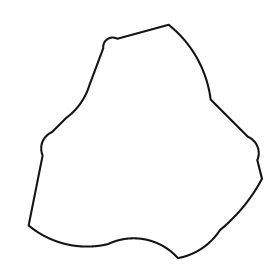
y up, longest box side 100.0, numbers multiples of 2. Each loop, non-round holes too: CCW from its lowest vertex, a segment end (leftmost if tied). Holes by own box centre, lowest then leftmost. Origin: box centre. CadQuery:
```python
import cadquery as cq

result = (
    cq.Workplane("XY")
    .moveTo(14.0, -50.0)
    .threePointArc((24.0, -46.0), (32.0, -38.0))
    .threePointArc((42.0, -28.0), (50.0, -16.0))
    .lineTo(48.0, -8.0)
    .threePointArc((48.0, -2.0), (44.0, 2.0))
    .lineTo(28.0, 18.0)
    .threePointArc((22.0, 36.0), (10.0, 50.0))
    .lineTo(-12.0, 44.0)
    .threePointArc((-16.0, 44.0), (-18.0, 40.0))
    .lineTo(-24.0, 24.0)
    .threePointArc((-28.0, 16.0), (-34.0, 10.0))
    .lineTo(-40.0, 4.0)
    .threePointArc((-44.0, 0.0), (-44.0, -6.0))
    .lineTo(-50.0, -36.0)
    .threePointArc((-34.0, -44.0), (-16.0, -44.0))
    .threePointArc((0.0, -42.0), (14.0, -50.0))
    .close()
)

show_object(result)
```